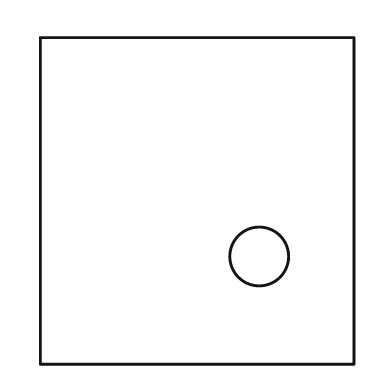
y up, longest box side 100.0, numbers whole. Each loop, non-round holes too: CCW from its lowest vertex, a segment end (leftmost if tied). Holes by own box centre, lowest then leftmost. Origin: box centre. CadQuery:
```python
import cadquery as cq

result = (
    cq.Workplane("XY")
    .moveTo(-48.0, -50.0)
    .lineTo(48.0, -50.0)
    .lineTo(48.0, 50.0)
    .lineTo(-48.0, 50.0)
    .close()
    .moveTo(19.0, -17.0)
    .circle(9.0)
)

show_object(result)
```